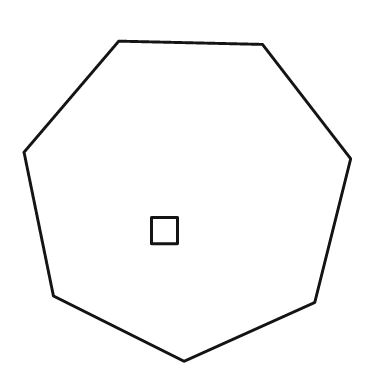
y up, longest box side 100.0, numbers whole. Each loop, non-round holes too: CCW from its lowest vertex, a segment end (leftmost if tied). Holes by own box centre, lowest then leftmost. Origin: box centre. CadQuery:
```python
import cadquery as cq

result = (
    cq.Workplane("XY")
    .moveTo(-1.0, -49.0)
    .lineTo(39.0, -31.0)
    .lineTo(50.0, 13.0)
    .lineTo(23.0, 48.0)
    .lineTo(-21.0, 49.0)
    .lineTo(-50.0, 15.0)
    .lineTo(-41.0, -29.0)
    .close()
    .moveTo(-11.0, -13.0)
    .lineTo(-3.0, -13.0)
    .lineTo(-3.0, -5.0)
    .lineTo(-11.0, -5.0)
    .close()
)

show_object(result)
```